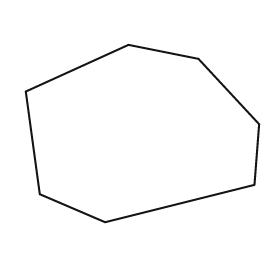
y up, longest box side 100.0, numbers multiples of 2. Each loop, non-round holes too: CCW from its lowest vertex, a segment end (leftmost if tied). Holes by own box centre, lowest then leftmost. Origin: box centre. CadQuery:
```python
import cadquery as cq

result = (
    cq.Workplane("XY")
    .moveTo(-16.0, -38.0)
    .lineTo(48.0, -22.0)
    .lineTo(50.0, 4.0)
    .lineTo(24.0, 32.0)
    .lineTo(-6.0, 38.0)
    .lineTo(-50.0, 18.0)
    .lineTo(-44.0, -26.0)
    .close()
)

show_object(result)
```